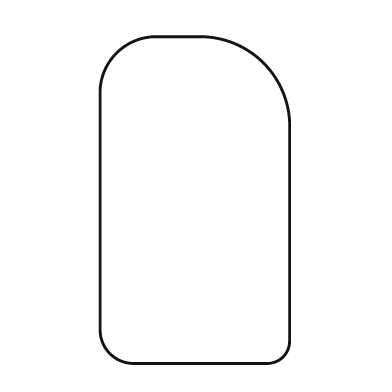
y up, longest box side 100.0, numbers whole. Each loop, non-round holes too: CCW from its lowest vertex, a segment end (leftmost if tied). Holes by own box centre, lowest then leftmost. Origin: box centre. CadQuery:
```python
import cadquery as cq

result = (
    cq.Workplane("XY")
    .moveTo(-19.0, -50.0)
    .lineTo(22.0, -50.0)
    .threePointArc((27.0, -48.0), (29.0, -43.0))
    .lineTo(29.0, 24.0)
    .threePointArc((21.0, 42.0), (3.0, 50.0))
    .lineTo(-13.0, 50.0)
    .threePointArc((-24.0, 45.0), (-29.0, 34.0))
    .lineTo(-29.0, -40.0)
    .threePointArc((-26.0, -47.0), (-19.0, -50.0))
    .close()
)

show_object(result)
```